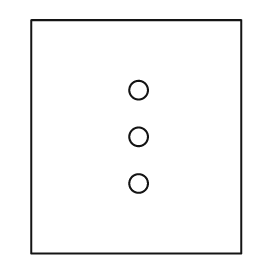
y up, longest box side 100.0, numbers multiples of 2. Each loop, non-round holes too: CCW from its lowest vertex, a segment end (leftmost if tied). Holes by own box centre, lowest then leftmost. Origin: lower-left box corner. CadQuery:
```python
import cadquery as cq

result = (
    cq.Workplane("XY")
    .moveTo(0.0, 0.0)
    .lineTo(90.0, 0.0)
    .lineTo(90.0, 100.0)
    .lineTo(0.0, 100.0)
    .close()
    .moveTo(46.0, 30.0)
    .circle(4.0)
    .moveTo(46.0, 50.0)
    .circle(4.0)
    .moveTo(46.0, 70.0)
    .circle(4.0)
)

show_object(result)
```